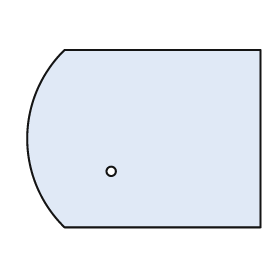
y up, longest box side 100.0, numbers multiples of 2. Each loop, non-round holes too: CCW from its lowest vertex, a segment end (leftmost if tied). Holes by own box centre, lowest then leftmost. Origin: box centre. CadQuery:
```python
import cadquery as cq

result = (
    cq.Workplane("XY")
    .moveTo(-34.0, -38.0)
    .lineTo(50.0, -38.0)
    .lineTo(50.0, 38.0)
    .lineTo(-34.0, 38.0)
    .threePointArc((-50.0, 0.0), (-34.0, -38.0))
    .close()
    .moveTo(-14.0, -14.0)
    .circle(2.0)
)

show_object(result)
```